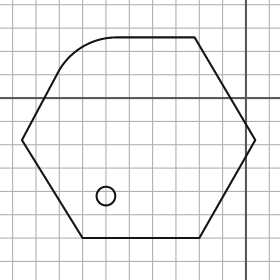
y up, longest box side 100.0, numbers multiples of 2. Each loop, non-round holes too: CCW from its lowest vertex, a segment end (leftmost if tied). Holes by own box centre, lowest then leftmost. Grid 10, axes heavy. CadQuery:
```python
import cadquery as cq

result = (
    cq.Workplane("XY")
    .moveTo(-70.0, -60.0)
    .lineTo(-20.0, -60.0)
    .lineTo(4.0, -18.0)
    .lineTo(-22.0, 26.0)
    .lineTo(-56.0, 26.0)
    .threePointArc((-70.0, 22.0), (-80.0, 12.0))
    .lineTo(-96.0, -18.0)
    .close()
    .moveTo(-60.0, -42.0)
    .circle(4.0)
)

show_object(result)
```